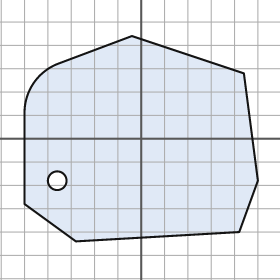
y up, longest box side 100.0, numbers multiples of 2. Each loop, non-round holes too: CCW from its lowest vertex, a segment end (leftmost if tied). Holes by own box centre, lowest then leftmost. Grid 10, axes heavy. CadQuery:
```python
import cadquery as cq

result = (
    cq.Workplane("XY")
    .moveTo(-28.0, -44.0)
    .lineTo(42.0, -40.0)
    .lineTo(50.0, -18.0)
    .lineTo(44.0, 28.0)
    .lineTo(-4.0, 44.0)
    .lineTo(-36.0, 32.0)
    .threePointArc((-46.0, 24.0), (-50.0, 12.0))
    .lineTo(-50.0, -28.0)
    .close()
    .moveTo(-36.0, -18.0)
    .circle(4.0)
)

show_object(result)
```